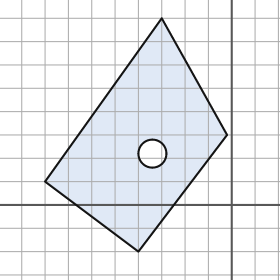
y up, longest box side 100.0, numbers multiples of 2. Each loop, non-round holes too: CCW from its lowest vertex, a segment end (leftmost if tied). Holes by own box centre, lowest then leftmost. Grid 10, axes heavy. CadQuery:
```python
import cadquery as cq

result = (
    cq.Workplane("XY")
    .moveTo(-40.0, -20.0)
    .lineTo(-2.0, 30.0)
    .lineTo(-30.0, 80.0)
    .lineTo(-80.0, 10.0)
    .close()
    .moveTo(-34.0, 22.0)
    .circle(6.0)
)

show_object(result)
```